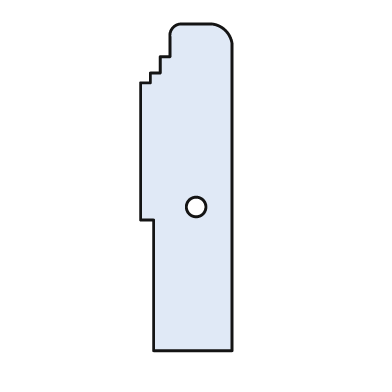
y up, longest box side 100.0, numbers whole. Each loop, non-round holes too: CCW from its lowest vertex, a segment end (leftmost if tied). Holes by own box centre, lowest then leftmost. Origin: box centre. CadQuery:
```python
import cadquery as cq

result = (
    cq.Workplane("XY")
    .moveTo(-10.0, -50.0)
    .lineTo(14.0, -50.0)
    .lineTo(14.0, 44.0)
    .threePointArc((12.0, 48.0), (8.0, 50.0))
    .lineTo(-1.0, 50.0)
    .threePointArc((-4.0, 49.0), (-5.0, 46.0))
    .lineTo(-5.0, 40.0)
    .lineTo(-8.0, 40.0)
    .lineTo(-8.0, 35.0)
    .lineTo(-11.0, 35.0)
    .lineTo(-11.0, 32.0)
    .lineTo(-14.0, 32.0)
    .lineTo(-14.0, -10.0)
    .lineTo(-10.0, -10.0)
    .close()
    .moveTo(3.0, -6.0)
    .circle(3.0)
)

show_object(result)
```